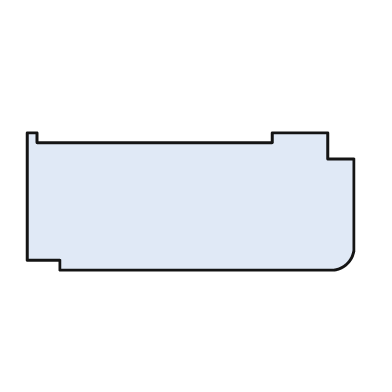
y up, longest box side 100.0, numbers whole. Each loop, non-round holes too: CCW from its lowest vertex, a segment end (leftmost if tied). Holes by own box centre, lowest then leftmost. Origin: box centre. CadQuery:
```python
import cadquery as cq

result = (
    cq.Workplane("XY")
    .moveTo(-40.0, -21.0)
    .lineTo(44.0, -21.0)
    .threePointArc((48.0, -19.0), (50.0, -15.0))
    .lineTo(50.0, 13.0)
    .lineTo(42.0, 13.0)
    .lineTo(42.0, 21.0)
    .lineTo(25.0, 21.0)
    .lineTo(25.0, 18.0)
    .lineTo(-47.0, 18.0)
    .lineTo(-47.0, 21.0)
    .lineTo(-50.0, 21.0)
    .lineTo(-50.0, -18.0)
    .lineTo(-40.0, -18.0)
    .close()
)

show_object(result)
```